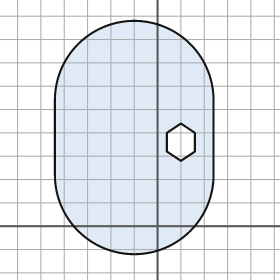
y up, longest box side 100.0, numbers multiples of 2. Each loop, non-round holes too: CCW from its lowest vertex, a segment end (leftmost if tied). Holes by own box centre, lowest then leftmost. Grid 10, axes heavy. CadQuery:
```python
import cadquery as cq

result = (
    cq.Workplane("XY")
    .moveTo(-44.0, 22.0)
    .threePointArc((-10.0, -12.0), (24.0, 22.0))
    .lineTo(24.0, 54.0)
    .threePointArc((-10.0, 88.0), (-44.0, 54.0))
    .close()
    .moveTo(10.0, 28.0)
    .lineTo(16.0, 32.0)
    .lineTo(16.0, 40.0)
    .lineTo(10.0, 44.0)
    .lineTo(4.0, 40.0)
    .lineTo(4.0, 32.0)
    .close()
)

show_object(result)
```